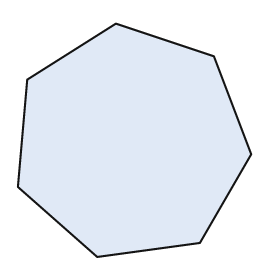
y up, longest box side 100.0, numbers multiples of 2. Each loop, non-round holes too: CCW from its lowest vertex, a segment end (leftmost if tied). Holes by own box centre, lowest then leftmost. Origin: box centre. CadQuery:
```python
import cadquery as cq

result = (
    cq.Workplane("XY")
    .moveTo(-16.0, -50.0)
    .lineTo(28.0, -44.0)
    .lineTo(50.0, -6.0)
    .lineTo(34.0, 36.0)
    .lineTo(-8.0, 50.0)
    .lineTo(-46.0, 26.0)
    .lineTo(-50.0, -20.0)
    .close()
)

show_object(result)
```